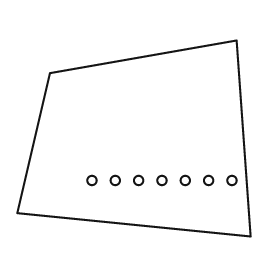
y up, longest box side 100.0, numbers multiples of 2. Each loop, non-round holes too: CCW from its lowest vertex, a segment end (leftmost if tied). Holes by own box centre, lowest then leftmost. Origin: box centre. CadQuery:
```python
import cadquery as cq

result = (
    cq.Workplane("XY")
    .moveTo(50.0, -42.0)
    .lineTo(44.0, 42.0)
    .lineTo(-36.0, 28.0)
    .lineTo(-50.0, -32.0)
    .close()
    .moveTo(-18.0, -18.0)
    .circle(2.0)
    .moveTo(-8.0, -18.0)
    .circle(2.0)
    .moveTo(2.0, -18.0)
    .circle(2.0)
    .moveTo(12.0, -18.0)
    .circle(2.0)
    .moveTo(22.0, -18.0)
    .circle(2.0)
    .moveTo(32.0, -18.0)
    .circle(2.0)
    .moveTo(42.0, -18.0)
    .circle(2.0)
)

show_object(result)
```